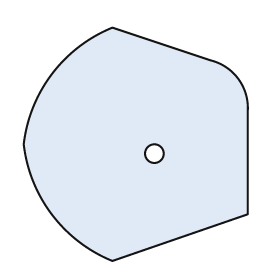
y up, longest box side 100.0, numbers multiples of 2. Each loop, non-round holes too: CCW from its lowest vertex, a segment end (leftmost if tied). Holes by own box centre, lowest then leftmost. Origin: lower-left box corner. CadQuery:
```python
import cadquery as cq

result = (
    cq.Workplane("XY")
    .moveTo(38.0, 0.0)
    .lineTo(96.0, 20.0)
    .lineTo(96.0, 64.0)
    .threePointArc((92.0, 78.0), (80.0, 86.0))
    .lineTo(38.0, 100.0)
    .threePointArc((12.0, 80.0), (0.0, 50.0))
    .threePointArc((12.0, 20.0), (38.0, 0.0))
    .close()
    .moveTo(56.0, 46.0)
    .circle(4.0)
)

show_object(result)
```